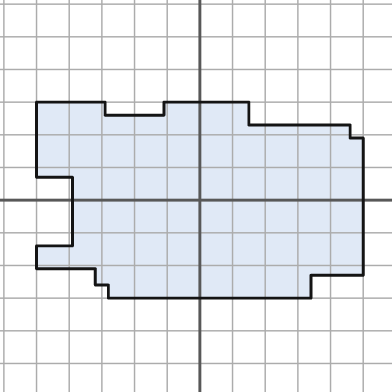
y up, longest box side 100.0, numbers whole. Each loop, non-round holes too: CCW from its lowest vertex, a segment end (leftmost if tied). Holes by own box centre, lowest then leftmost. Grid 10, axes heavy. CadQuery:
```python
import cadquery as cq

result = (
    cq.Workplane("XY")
    .moveTo(-28.0, -30.0)
    .lineTo(34.0, -30.0)
    .lineTo(34.0, -23.0)
    .lineTo(50.0, -23.0)
    .lineTo(50.0, 19.0)
    .lineTo(46.0, 19.0)
    .lineTo(46.0, 23.0)
    .lineTo(15.0, 23.0)
    .lineTo(15.0, 30.0)
    .lineTo(-11.0, 30.0)
    .lineTo(-11.0, 26.0)
    .lineTo(-29.0, 26.0)
    .lineTo(-29.0, 30.0)
    .lineTo(-50.0, 30.0)
    .lineTo(-50.0, 7.0)
    .lineTo(-39.0, 7.0)
    .lineTo(-39.0, -14.0)
    .lineTo(-50.0, -14.0)
    .lineTo(-50.0, -21.0)
    .lineTo(-32.0, -21.0)
    .lineTo(-32.0, -26.0)
    .lineTo(-28.0, -26.0)
    .close()
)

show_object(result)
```